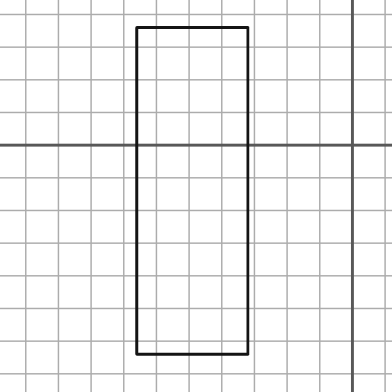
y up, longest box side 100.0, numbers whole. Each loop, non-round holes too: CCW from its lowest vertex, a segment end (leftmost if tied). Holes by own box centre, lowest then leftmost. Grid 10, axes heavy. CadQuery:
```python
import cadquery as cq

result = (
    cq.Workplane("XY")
    .moveTo(-66.0, -64.0)
    .lineTo(-32.0, -64.0)
    .lineTo(-32.0, 36.0)
    .lineTo(-66.0, 36.0)
    .close()
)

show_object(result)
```